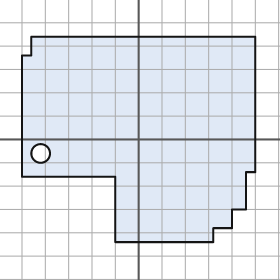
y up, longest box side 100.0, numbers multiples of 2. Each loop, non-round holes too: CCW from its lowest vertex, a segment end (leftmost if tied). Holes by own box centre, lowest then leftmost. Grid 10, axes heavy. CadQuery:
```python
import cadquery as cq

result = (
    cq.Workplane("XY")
    .moveTo(-10.0, -44.0)
    .lineTo(32.0, -44.0)
    .lineTo(32.0, -38.0)
    .lineTo(40.0, -38.0)
    .lineTo(40.0, -30.0)
    .lineTo(46.0, -30.0)
    .lineTo(46.0, -14.0)
    .lineTo(50.0, -14.0)
    .lineTo(50.0, 44.0)
    .lineTo(-46.0, 44.0)
    .lineTo(-46.0, 36.0)
    .lineTo(-50.0, 36.0)
    .lineTo(-50.0, -16.0)
    .lineTo(-10.0, -16.0)
    .close()
    .moveTo(-42.0, -6.0)
    .circle(4.0)
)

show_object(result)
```